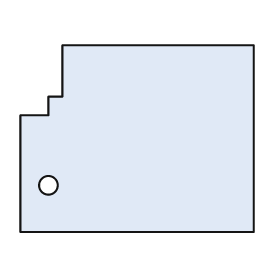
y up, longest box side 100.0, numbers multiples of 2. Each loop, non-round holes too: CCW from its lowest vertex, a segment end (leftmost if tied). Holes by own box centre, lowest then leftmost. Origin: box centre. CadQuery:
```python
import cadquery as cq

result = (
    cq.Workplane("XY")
    .moveTo(-50.0, -40.0)
    .lineTo(50.0, -40.0)
    .lineTo(50.0, 40.0)
    .lineTo(-32.0, 40.0)
    .lineTo(-32.0, 18.0)
    .lineTo(-38.0, 18.0)
    .lineTo(-38.0, 10.0)
    .lineTo(-50.0, 10.0)
    .close()
    .moveTo(-38.0, -20.0)
    .circle(4.0)
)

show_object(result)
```